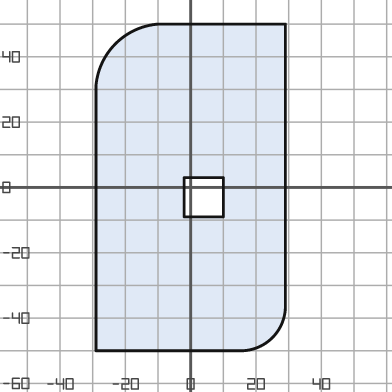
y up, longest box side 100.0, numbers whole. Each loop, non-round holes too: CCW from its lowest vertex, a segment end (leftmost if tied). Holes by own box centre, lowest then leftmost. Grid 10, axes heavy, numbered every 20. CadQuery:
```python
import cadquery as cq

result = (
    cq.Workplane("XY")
    .moveTo(-29.0, -50.0)
    .lineTo(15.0, -50.0)
    .threePointArc((25.0, -46.0), (29.0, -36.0))
    .lineTo(29.0, 50.0)
    .lineTo(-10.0, 50.0)
    .threePointArc((-23.0, 44.0), (-29.0, 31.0))
    .close()
    .moveTo(-2.0, -9.0)
    .lineTo(10.0, -9.0)
    .lineTo(10.0, 3.0)
    .lineTo(-2.0, 3.0)
    .close()
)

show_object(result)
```